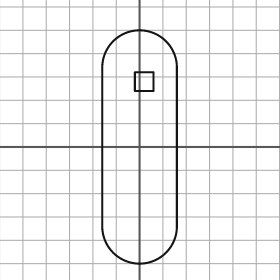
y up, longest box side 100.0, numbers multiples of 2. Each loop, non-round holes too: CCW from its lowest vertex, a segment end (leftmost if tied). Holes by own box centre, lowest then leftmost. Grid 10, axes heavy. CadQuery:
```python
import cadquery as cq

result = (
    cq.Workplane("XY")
    .moveTo(-16.0, -34.0)
    .threePointArc((0.0, -50.0), (16.0, -34.0))
    .lineTo(16.0, 34.0)
    .threePointArc((0.0, 50.0), (-16.0, 34.0))
    .close()
    .moveTo(-2.0, 24.0)
    .lineTo(6.0, 24.0)
    .lineTo(6.0, 32.0)
    .lineTo(-2.0, 32.0)
    .close()
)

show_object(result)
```